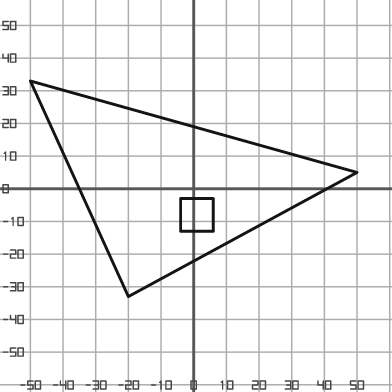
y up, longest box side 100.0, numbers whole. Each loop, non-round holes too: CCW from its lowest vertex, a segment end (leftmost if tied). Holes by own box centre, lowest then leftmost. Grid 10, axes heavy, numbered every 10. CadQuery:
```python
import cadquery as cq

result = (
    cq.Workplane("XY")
    .moveTo(-20.0, -33.0)
    .lineTo(50.0, 5.0)
    .lineTo(-50.0, 33.0)
    .close()
    .moveTo(-4.0, -13.0)
    .lineTo(6.0, -13.0)
    .lineTo(6.0, -3.0)
    .lineTo(-4.0, -3.0)
    .close()
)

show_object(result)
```